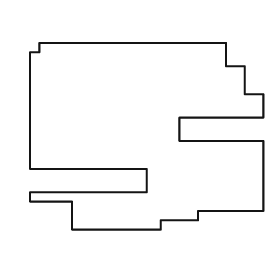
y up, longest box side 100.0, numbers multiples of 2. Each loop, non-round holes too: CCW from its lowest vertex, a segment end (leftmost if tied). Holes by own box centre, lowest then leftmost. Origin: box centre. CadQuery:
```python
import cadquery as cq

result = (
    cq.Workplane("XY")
    .moveTo(-32.0, -40.0)
    .lineTo(6.0, -40.0)
    .lineTo(6.0, -36.0)
    .lineTo(22.0, -36.0)
    .lineTo(22.0, -32.0)
    .lineTo(50.0, -32.0)
    .lineTo(50.0, -2.0)
    .lineTo(14.0, -2.0)
    .lineTo(14.0, 8.0)
    .lineTo(50.0, 8.0)
    .lineTo(50.0, 18.0)
    .lineTo(42.0, 18.0)
    .lineTo(42.0, 30.0)
    .lineTo(34.0, 30.0)
    .lineTo(34.0, 40.0)
    .lineTo(-46.0, 40.0)
    .lineTo(-46.0, 36.0)
    .lineTo(-50.0, 36.0)
    .lineTo(-50.0, -14.0)
    .lineTo(0.0, -14.0)
    .lineTo(0.0, -24.0)
    .lineTo(-50.0, -24.0)
    .lineTo(-50.0, -28.0)
    .lineTo(-32.0, -28.0)
    .close()
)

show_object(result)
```